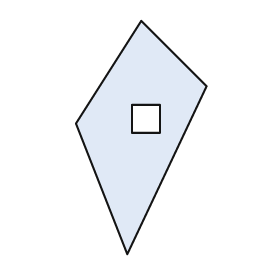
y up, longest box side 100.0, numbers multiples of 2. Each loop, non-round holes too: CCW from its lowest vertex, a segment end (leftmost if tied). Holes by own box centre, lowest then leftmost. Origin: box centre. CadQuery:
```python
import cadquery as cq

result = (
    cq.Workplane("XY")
    .moveTo(-6.0, -50.0)
    .lineTo(28.0, 22.0)
    .lineTo(0.0, 50.0)
    .lineTo(-28.0, 6.0)
    .close()
    .moveTo(-4.0, 2.0)
    .lineTo(8.0, 2.0)
    .lineTo(8.0, 14.0)
    .lineTo(-4.0, 14.0)
    .close()
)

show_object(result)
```